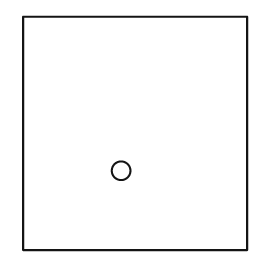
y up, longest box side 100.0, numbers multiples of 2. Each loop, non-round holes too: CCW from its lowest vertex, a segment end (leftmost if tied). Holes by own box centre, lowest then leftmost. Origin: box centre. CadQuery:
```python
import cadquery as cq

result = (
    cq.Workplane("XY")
    .moveTo(-48.0, -50.0)
    .lineTo(48.0, -50.0)
    .lineTo(48.0, 50.0)
    .lineTo(-48.0, 50.0)
    .close()
    .moveTo(-6.0, -16.0)
    .circle(4.0)
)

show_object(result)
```